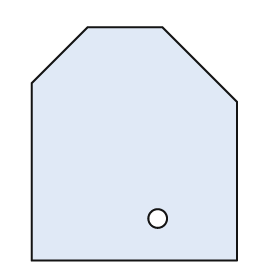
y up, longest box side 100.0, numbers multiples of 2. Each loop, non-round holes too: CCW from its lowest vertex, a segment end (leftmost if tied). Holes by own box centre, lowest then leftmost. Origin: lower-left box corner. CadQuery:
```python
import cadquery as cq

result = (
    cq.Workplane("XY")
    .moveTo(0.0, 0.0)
    .lineTo(88.0, 0.0)
    .lineTo(88.0, 68.0)
    .lineTo(56.0, 100.0)
    .lineTo(24.0, 100.0)
    .lineTo(0.0, 76.0)
    .close()
    .moveTo(54.0, 18.0)
    .circle(4.0)
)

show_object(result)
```